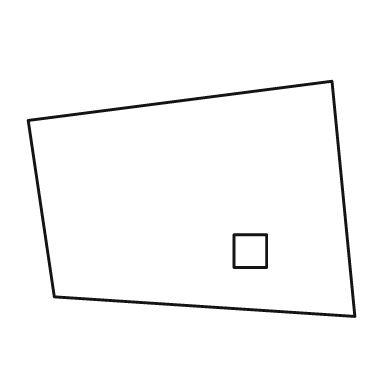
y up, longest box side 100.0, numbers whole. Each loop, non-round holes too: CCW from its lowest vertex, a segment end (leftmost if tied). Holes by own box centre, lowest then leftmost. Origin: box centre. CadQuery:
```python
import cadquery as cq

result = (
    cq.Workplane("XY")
    .moveTo(50.0, -36.0)
    .lineTo(43.0, 36.0)
    .lineTo(-50.0, 24.0)
    .lineTo(-42.0, -30.0)
    .close()
    .moveTo(13.0, -21.0)
    .lineTo(23.0, -21.0)
    .lineTo(23.0, -11.0)
    .lineTo(13.0, -11.0)
    .close()
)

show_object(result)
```